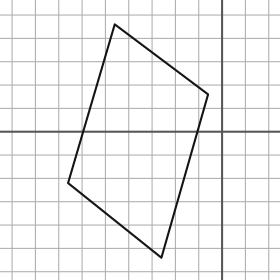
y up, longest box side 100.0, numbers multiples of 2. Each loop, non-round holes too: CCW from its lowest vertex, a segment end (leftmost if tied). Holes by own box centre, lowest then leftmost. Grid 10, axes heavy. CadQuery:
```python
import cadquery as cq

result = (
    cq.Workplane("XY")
    .moveTo(-26.0, -54.0)
    .lineTo(-6.0, 16.0)
    .lineTo(-46.0, 46.0)
    .lineTo(-66.0, -22.0)
    .close()
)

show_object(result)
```